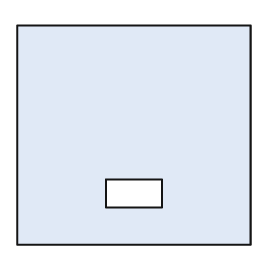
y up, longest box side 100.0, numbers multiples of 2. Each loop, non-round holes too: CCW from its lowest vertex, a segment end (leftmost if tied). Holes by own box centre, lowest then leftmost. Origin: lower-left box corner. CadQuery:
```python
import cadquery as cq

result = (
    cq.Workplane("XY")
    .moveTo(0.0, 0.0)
    .lineTo(100.0, 0.0)
    .lineTo(100.0, 94.0)
    .lineTo(0.0, 94.0)
    .close()
    .moveTo(38.0, 16.0)
    .lineTo(62.0, 16.0)
    .lineTo(62.0, 28.0)
    .lineTo(38.0, 28.0)
    .close()
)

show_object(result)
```